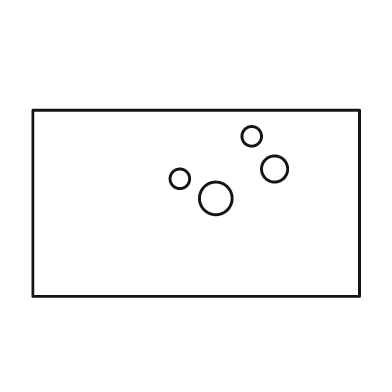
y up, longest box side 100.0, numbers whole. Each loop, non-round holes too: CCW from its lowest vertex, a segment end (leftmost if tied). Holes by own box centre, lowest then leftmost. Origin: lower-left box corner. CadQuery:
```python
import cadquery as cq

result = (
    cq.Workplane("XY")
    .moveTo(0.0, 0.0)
    .lineTo(100.0, 0.0)
    .lineTo(100.0, 57.0)
    .lineTo(0.0, 57.0)
    .close()
    .moveTo(56.0, 30.0)
    .circle(5.0)
    .moveTo(45.0, 36.0)
    .circle(3.0)
    .moveTo(74.0, 39.0)
    .circle(4.0)
    .moveTo(67.0, 49.0)
    .circle(3.0)
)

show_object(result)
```